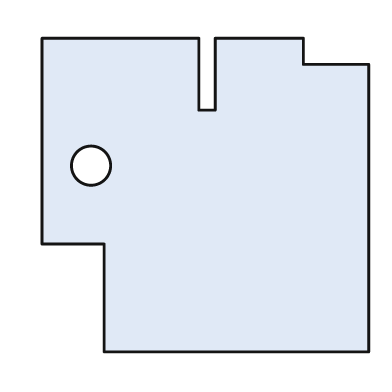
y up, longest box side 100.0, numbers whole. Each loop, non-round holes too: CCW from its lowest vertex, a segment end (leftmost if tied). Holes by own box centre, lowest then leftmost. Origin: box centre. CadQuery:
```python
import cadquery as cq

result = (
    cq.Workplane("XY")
    .moveTo(-31.0, -48.0)
    .lineTo(50.0, -48.0)
    .lineTo(50.0, 40.0)
    .lineTo(30.0, 40.0)
    .lineTo(30.0, 48.0)
    .lineTo(3.0, 48.0)
    .lineTo(3.0, 26.0)
    .lineTo(-2.0, 26.0)
    .lineTo(-2.0, 48.0)
    .lineTo(-50.0, 48.0)
    .lineTo(-50.0, -15.0)
    .lineTo(-31.0, -15.0)
    .close()
    .moveTo(-35.0, 9.0)
    .circle(6.0)
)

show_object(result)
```